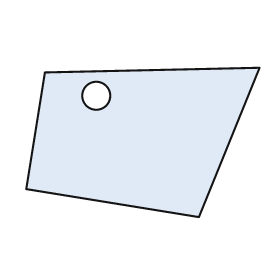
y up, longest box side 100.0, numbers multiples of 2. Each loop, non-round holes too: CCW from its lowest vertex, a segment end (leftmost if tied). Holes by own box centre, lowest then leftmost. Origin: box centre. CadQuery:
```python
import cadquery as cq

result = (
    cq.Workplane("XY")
    .moveTo(24.0, -32.0)
    .lineTo(50.0, 32.0)
    .lineTo(-42.0, 30.0)
    .lineTo(-50.0, -20.0)
    .close()
    .moveTo(-20.0, 20.0)
    .circle(6.0)
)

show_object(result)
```